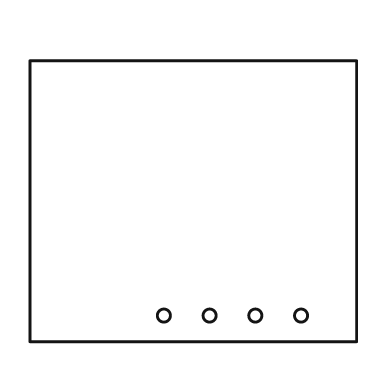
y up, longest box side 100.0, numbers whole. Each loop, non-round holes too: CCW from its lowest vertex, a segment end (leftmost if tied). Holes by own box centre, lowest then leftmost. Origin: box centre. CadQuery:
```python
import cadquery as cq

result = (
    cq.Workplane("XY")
    .moveTo(-50.0, -43.0)
    .lineTo(50.0, -43.0)
    .lineTo(50.0, 43.0)
    .lineTo(-50.0, 43.0)
    .close()
    .moveTo(-9.0, -35.0)
    .circle(2.0)
    .moveTo(5.0, -35.0)
    .circle(2.0)
    .moveTo(19.0, -35.0)
    .circle(2.0)
    .moveTo(33.0, -35.0)
    .circle(2.0)
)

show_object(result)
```